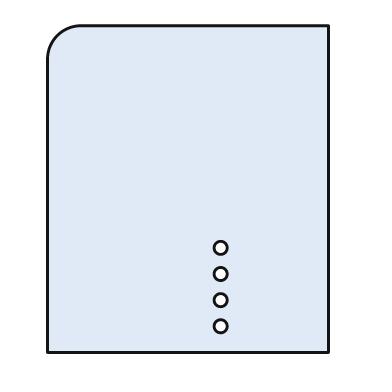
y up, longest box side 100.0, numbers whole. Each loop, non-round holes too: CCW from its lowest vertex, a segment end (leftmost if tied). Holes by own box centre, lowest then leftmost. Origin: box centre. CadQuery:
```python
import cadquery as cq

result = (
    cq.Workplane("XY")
    .moveTo(-43.0, -50.0)
    .lineTo(43.0, -50.0)
    .lineTo(43.0, 50.0)
    .lineTo(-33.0, 50.0)
    .threePointArc((-40.0, 47.0), (-43.0, 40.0))
    .close()
    .moveTo(10.0, -42.0)
    .circle(2.0)
    .moveTo(10.0, -34.0)
    .circle(2.0)
    .moveTo(10.0, -26.0)
    .circle(2.0)
    .moveTo(10.0, -18.0)
    .circle(2.0)
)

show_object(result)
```